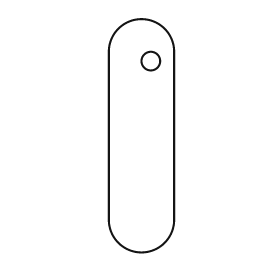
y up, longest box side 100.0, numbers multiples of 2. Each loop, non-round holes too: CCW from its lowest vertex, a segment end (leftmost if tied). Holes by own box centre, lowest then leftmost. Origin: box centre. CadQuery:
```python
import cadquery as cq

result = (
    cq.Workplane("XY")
    .moveTo(-14.0, -36.0)
    .threePointArc((0.0, -50.0), (14.0, -36.0))
    .lineTo(14.0, 36.0)
    .threePointArc((0.0, 50.0), (-14.0, 36.0))
    .close()
    .moveTo(4.0, 32.0)
    .circle(4.0)
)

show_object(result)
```